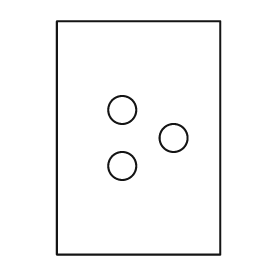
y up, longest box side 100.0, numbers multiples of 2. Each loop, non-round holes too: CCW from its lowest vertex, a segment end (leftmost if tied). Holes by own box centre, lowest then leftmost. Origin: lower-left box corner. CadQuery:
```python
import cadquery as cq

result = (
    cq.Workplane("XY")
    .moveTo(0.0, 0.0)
    .lineTo(70.0, 0.0)
    .lineTo(70.0, 100.0)
    .lineTo(0.0, 100.0)
    .close()
    .moveTo(28.0, 38.0)
    .circle(6.0)
    .moveTo(50.0, 50.0)
    .circle(6.0)
    .moveTo(28.0, 62.0)
    .circle(6.0)
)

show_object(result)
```